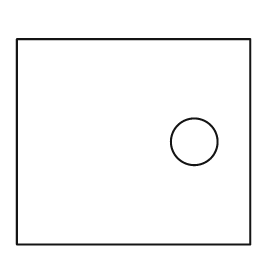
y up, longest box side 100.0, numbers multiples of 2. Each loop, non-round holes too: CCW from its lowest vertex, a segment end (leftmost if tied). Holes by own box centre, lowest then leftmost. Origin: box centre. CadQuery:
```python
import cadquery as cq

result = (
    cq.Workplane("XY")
    .moveTo(-50.0, -44.0)
    .lineTo(50.0, -44.0)
    .lineTo(50.0, 44.0)
    .lineTo(-50.0, 44.0)
    .close()
    .moveTo(26.0, 0.0)
    .circle(10.0)
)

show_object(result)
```